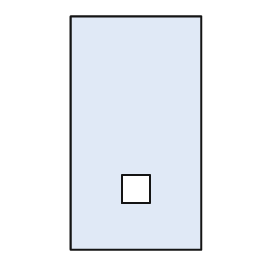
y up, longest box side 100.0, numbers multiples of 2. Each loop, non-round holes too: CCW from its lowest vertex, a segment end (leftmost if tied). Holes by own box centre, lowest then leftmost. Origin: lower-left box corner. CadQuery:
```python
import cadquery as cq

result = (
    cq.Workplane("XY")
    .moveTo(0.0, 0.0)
    .lineTo(56.0, 0.0)
    .lineTo(56.0, 100.0)
    .lineTo(0.0, 100.0)
    .close()
    .moveTo(22.0, 20.0)
    .lineTo(34.0, 20.0)
    .lineTo(34.0, 32.0)
    .lineTo(22.0, 32.0)
    .close()
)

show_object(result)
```